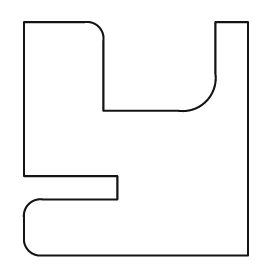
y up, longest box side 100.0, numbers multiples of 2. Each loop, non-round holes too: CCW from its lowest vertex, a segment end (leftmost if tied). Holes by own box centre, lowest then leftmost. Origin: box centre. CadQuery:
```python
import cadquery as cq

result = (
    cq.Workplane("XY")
    .moveTo(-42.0, -50.0)
    .lineTo(48.0, -50.0)
    .lineTo(48.0, 50.0)
    .lineTo(34.0, 50.0)
    .lineTo(34.0, 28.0)
    .threePointArc((30.0, 16.0), (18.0, 12.0))
    .lineTo(-14.0, 12.0)
    .lineTo(-14.0, 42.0)
    .threePointArc((-16.0, 48.0), (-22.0, 50.0))
    .lineTo(-48.0, 50.0)
    .lineTo(-48.0, -16.0)
    .lineTo(-8.0, -16.0)
    .lineTo(-8.0, -26.0)
    .lineTo(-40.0, -26.0)
    .threePointArc((-46.0, -28.0), (-48.0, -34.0))
    .lineTo(-48.0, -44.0)
    .threePointArc((-46.0, -48.0), (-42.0, -50.0))
    .close()
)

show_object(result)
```